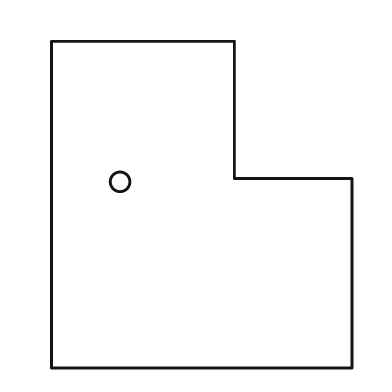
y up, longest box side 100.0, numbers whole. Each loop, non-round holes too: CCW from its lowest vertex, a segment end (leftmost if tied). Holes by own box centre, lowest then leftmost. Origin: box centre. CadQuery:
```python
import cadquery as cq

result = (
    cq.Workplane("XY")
    .moveTo(-46.0, -50.0)
    .lineTo(46.0, -50.0)
    .lineTo(46.0, 8.0)
    .lineTo(10.0, 8.0)
    .lineTo(10.0, 50.0)
    .lineTo(-46.0, 50.0)
    .close()
    .moveTo(-25.0, 7.0)
    .circle(3.0)
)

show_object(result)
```